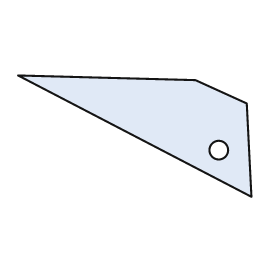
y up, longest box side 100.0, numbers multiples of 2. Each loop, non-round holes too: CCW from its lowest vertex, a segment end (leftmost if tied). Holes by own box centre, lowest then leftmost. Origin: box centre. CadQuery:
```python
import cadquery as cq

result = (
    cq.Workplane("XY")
    .moveTo(50.0, -26.0)
    .lineTo(48.0, 14.0)
    .lineTo(26.0, 24.0)
    .lineTo(-50.0, 26.0)
    .close()
    .moveTo(36.0, -6.0)
    .circle(4.0)
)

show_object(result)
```